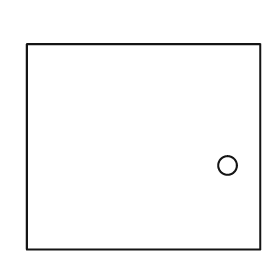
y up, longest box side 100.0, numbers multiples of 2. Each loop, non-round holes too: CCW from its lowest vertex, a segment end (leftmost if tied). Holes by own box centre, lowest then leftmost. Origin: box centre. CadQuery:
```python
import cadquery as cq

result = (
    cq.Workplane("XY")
    .moveTo(-50.0, -44.0)
    .lineTo(50.0, -44.0)
    .lineTo(50.0, 44.0)
    .lineTo(-50.0, 44.0)
    .close()
    .moveTo(36.0, -8.0)
    .circle(4.0)
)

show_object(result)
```